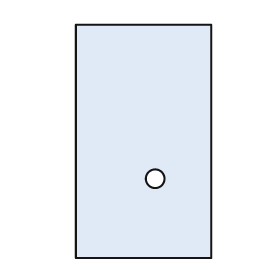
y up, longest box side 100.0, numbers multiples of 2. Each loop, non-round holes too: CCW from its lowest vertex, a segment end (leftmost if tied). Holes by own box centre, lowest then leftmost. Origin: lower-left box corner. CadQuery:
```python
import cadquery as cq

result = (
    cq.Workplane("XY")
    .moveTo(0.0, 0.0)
    .lineTo(58.0, 0.0)
    .lineTo(58.0, 100.0)
    .lineTo(0.0, 100.0)
    .close()
    .moveTo(34.0, 34.0)
    .circle(4.0)
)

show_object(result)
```